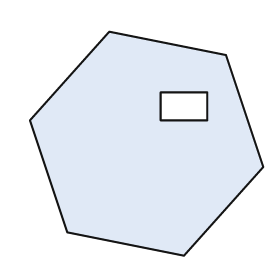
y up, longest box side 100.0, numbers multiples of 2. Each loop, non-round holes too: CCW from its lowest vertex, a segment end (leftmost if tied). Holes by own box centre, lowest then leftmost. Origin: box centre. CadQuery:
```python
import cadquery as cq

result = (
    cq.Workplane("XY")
    .moveTo(16.0, -48.0)
    .lineTo(50.0, -10.0)
    .lineTo(34.0, 38.0)
    .lineTo(-16.0, 48.0)
    .lineTo(-50.0, 10.0)
    .lineTo(-34.0, -38.0)
    .close()
    .moveTo(6.0, 10.0)
    .lineTo(26.0, 10.0)
    .lineTo(26.0, 22.0)
    .lineTo(6.0, 22.0)
    .close()
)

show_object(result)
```